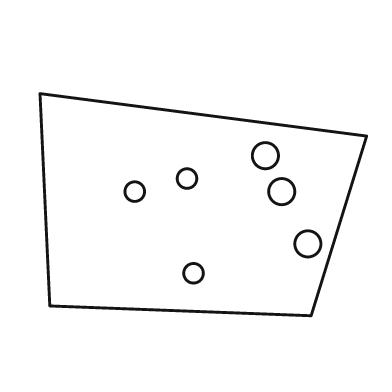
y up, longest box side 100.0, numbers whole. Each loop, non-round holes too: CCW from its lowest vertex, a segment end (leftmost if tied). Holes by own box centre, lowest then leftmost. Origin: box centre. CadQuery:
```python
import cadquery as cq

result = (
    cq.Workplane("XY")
    .moveTo(33.0, -34.0)
    .lineTo(50.0, 21.0)
    .lineTo(-50.0, 34.0)
    .lineTo(-47.0, -31.0)
    .close()
    .moveTo(-3.0, -21.0)
    .circle(3.0)
    .moveTo(32.0, -12.0)
    .circle(4.0)
    .moveTo(-21.0, 4.0)
    .circle(3.0)
    .moveTo(24.0, 4.0)
    .circle(4.0)
    .moveTo(-5.0, 8.0)
    .circle(3.0)
    .moveTo(19.0, 15.0)
    .circle(4.0)
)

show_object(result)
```